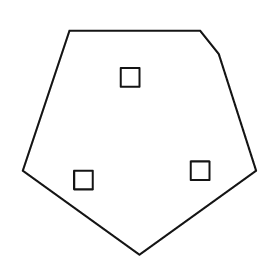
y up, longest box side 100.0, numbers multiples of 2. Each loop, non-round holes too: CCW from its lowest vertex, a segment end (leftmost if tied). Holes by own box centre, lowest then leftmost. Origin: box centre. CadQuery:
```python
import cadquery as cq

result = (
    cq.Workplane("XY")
    .moveTo(0.0, -48.0)
    .lineTo(50.0, -12.0)
    .lineTo(34.0, 38.0)
    .lineTo(26.0, 48.0)
    .lineTo(-30.0, 48.0)
    .lineTo(-50.0, -12.0)
    .close()
    .moveTo(-28.0, -20.0)
    .lineTo(-20.0, -20.0)
    .lineTo(-20.0, -12.0)
    .lineTo(-28.0, -12.0)
    .close()
    .moveTo(22.0, -16.0)
    .lineTo(30.0, -16.0)
    .lineTo(30.0, -8.0)
    .lineTo(22.0, -8.0)
    .close()
    .moveTo(-8.0, 24.0)
    .lineTo(0.0, 24.0)
    .lineTo(0.0, 32.0)
    .lineTo(-8.0, 32.0)
    .close()
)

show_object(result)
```